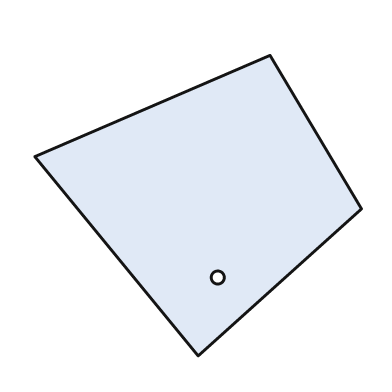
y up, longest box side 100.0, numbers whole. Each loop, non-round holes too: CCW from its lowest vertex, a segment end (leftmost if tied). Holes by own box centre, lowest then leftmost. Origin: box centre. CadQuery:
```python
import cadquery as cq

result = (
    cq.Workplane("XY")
    .moveTo(0.0, -46.0)
    .lineTo(50.0, -1.0)
    .lineTo(22.0, 46.0)
    .lineTo(-50.0, 15.0)
    .close()
    .moveTo(6.0, -22.0)
    .circle(2.0)
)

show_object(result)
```